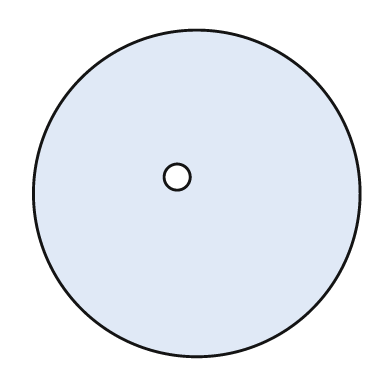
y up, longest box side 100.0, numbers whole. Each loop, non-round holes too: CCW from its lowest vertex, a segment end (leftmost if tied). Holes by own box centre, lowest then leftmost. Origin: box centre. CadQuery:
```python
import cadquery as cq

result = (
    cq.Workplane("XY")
    .moveTo(0.0, 0.0)
    .circle(50.0)
    .moveTo(-6.0, 5.0)
    .circle(4.0)
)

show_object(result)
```